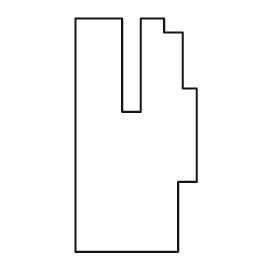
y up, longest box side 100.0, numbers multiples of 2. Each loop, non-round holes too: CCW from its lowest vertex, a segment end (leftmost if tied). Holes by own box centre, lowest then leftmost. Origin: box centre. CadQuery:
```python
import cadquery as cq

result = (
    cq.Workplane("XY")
    .moveTo(-26.0, -50.0)
    .lineTo(18.0, -50.0)
    .lineTo(18.0, -20.0)
    .lineTo(26.0, -20.0)
    .lineTo(26.0, 20.0)
    .lineTo(20.0, 20.0)
    .lineTo(20.0, 44.0)
    .lineTo(12.0, 44.0)
    .lineTo(12.0, 50.0)
    .lineTo(2.0, 50.0)
    .lineTo(2.0, 10.0)
    .lineTo(-6.0, 10.0)
    .lineTo(-6.0, 50.0)
    .lineTo(-26.0, 50.0)
    .close()
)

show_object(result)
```